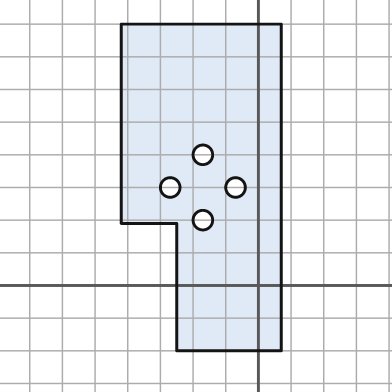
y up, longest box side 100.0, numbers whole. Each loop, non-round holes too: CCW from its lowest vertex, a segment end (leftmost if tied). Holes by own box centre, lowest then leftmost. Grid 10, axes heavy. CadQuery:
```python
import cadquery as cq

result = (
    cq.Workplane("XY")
    .moveTo(-25.0, -20.0)
    .lineTo(7.0, -20.0)
    .lineTo(7.0, 80.0)
    .lineTo(-42.0, 80.0)
    .lineTo(-42.0, 19.0)
    .lineTo(-25.0, 19.0)
    .close()
    .moveTo(-17.0, 20.0)
    .circle(3.0)
    .moveTo(-27.0, 30.0)
    .circle(3.0)
    .moveTo(-7.0, 30.0)
    .circle(3.0)
    .moveTo(-17.0, 40.0)
    .circle(3.0)
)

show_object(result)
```